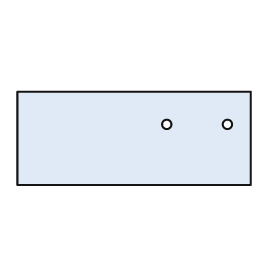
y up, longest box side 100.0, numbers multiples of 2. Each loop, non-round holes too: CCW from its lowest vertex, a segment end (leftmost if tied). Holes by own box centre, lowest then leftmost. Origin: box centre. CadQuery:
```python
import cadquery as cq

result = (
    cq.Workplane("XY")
    .moveTo(-50.0, -20.0)
    .lineTo(50.0, -20.0)
    .lineTo(50.0, 20.0)
    .lineTo(-50.0, 20.0)
    .close()
    .moveTo(14.0, 6.0)
    .circle(2.0)
    .moveTo(40.0, 6.0)
    .circle(2.0)
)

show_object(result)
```